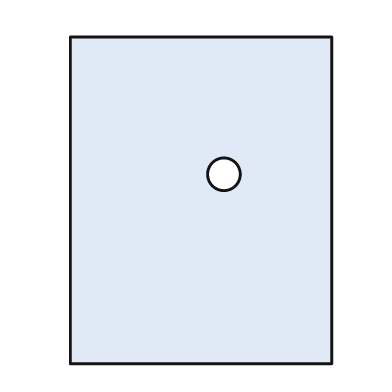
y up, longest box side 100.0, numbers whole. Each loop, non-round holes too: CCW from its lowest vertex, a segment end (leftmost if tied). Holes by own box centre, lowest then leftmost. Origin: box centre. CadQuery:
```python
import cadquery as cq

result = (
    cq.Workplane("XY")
    .moveTo(-40.0, -50.0)
    .lineTo(40.0, -50.0)
    .lineTo(40.0, 50.0)
    .lineTo(-40.0, 50.0)
    .close()
    .moveTo(7.0, 8.0)
    .circle(5.0)
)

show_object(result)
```